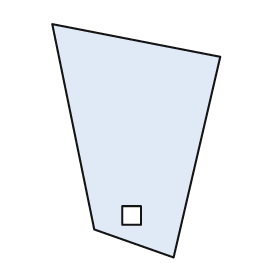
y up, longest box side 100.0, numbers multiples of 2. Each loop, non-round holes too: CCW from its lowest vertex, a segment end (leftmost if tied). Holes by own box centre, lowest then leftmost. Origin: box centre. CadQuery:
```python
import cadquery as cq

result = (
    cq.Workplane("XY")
    .moveTo(16.0, -50.0)
    .lineTo(36.0, 36.0)
    .lineTo(-36.0, 50.0)
    .lineTo(-18.0, -38.0)
    .close()
    .moveTo(-6.0, -36.0)
    .lineTo(2.0, -36.0)
    .lineTo(2.0, -28.0)
    .lineTo(-6.0, -28.0)
    .close()
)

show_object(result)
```